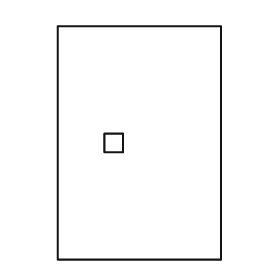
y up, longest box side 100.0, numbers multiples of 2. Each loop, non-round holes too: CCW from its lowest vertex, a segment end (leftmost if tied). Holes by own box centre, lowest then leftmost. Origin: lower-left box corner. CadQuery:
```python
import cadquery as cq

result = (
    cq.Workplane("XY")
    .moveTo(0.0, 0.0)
    .lineTo(70.0, 0.0)
    .lineTo(70.0, 100.0)
    .lineTo(0.0, 100.0)
    .close()
    .moveTo(20.0, 46.0)
    .lineTo(28.0, 46.0)
    .lineTo(28.0, 54.0)
    .lineTo(20.0, 54.0)
    .close()
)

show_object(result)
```